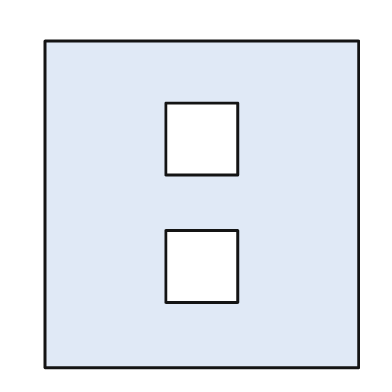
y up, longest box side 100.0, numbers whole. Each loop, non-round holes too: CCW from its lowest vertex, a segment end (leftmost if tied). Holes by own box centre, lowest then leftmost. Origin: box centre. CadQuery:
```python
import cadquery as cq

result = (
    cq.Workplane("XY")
    .moveTo(-48.0, -50.0)
    .lineTo(48.0, -50.0)
    .lineTo(48.0, 50.0)
    .lineTo(-48.0, 50.0)
    .close()
    .moveTo(-11.0, -30.0)
    .lineTo(11.0, -30.0)
    .lineTo(11.0, -8.0)
    .lineTo(-11.0, -8.0)
    .close()
    .moveTo(-11.0, 9.0)
    .lineTo(11.0, 9.0)
    .lineTo(11.0, 31.0)
    .lineTo(-11.0, 31.0)
    .close()
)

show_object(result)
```